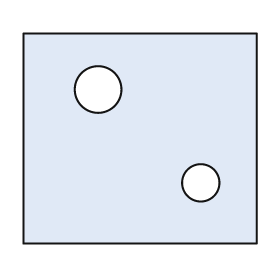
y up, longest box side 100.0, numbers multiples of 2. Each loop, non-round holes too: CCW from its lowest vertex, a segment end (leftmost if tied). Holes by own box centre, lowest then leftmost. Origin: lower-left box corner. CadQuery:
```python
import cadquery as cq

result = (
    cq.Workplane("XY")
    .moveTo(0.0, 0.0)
    .lineTo(100.0, 0.0)
    .lineTo(100.0, 90.0)
    .lineTo(0.0, 90.0)
    .close()
    .moveTo(76.0, 26.0)
    .circle(8.0)
    .moveTo(32.0, 66.0)
    .circle(10.0)
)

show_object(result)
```